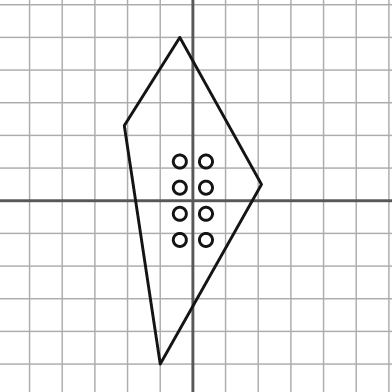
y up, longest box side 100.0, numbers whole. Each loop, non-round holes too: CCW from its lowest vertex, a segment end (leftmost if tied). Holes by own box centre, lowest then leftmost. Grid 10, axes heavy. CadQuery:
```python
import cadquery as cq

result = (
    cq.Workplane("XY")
    .moveTo(-10.0, -50.0)
    .lineTo(21.0, 5.0)
    .lineTo(-4.0, 50.0)
    .lineTo(-21.0, 23.0)
    .close()
    .moveTo(-4.0, -12.0)
    .circle(2.0)
    .moveTo(4.0, -12.0)
    .circle(2.0)
    .moveTo(-4.0, -4.0)
    .circle(2.0)
    .moveTo(4.0, -4.0)
    .circle(2.0)
    .moveTo(-4.0, 4.0)
    .circle(2.0)
    .moveTo(4.0, 4.0)
    .circle(2.0)
    .moveTo(-4.0, 12.0)
    .circle(2.0)
    .moveTo(4.0, 12.0)
    .circle(2.0)
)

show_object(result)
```